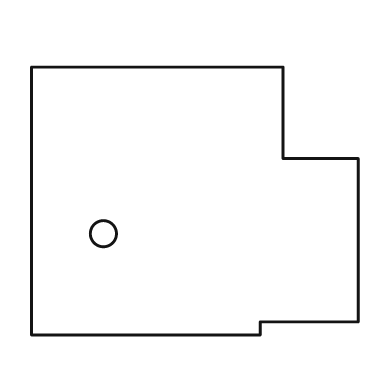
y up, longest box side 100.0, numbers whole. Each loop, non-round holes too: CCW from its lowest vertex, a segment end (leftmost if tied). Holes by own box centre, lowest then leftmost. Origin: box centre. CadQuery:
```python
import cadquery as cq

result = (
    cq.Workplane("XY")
    .moveTo(-50.0, -41.0)
    .lineTo(20.0, -41.0)
    .lineTo(20.0, -37.0)
    .lineTo(50.0, -37.0)
    .lineTo(50.0, 13.0)
    .lineTo(27.0, 13.0)
    .lineTo(27.0, 41.0)
    .lineTo(-50.0, 41.0)
    .close()
    .moveTo(-28.0, -10.0)
    .circle(4.0)
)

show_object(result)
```